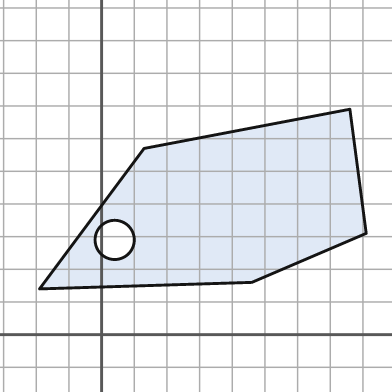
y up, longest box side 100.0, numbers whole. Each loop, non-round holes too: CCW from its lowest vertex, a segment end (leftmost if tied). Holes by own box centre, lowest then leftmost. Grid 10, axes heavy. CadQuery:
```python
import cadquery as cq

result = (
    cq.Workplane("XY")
    .moveTo(-19.0, 14.0)
    .lineTo(46.0, 16.0)
    .lineTo(81.0, 31.0)
    .lineTo(76.0, 69.0)
    .lineTo(13.0, 57.0)
    .close()
    .moveTo(4.0, 29.0)
    .circle(6.0)
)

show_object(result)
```